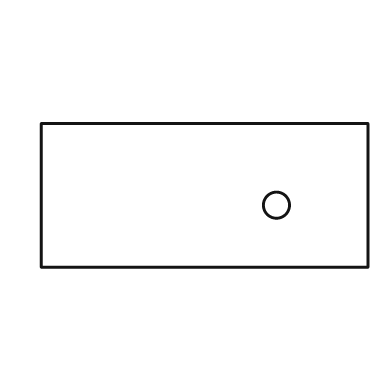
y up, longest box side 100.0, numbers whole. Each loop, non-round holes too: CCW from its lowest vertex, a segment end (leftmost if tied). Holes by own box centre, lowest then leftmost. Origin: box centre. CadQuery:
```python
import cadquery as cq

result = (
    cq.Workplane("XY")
    .moveTo(-50.0, -22.0)
    .lineTo(50.0, -22.0)
    .lineTo(50.0, 22.0)
    .lineTo(-50.0, 22.0)
    .close()
    .moveTo(22.0, -3.0)
    .circle(4.0)
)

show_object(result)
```